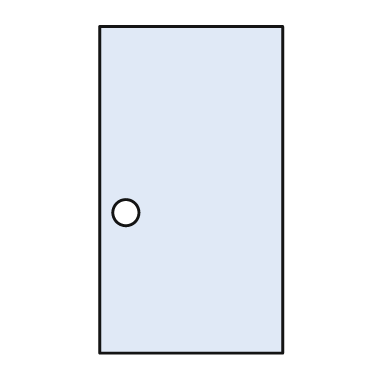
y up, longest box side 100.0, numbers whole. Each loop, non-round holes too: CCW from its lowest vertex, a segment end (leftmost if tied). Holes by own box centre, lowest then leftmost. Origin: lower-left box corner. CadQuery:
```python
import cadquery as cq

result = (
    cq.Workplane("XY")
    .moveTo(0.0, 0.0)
    .lineTo(56.0, 0.0)
    .lineTo(56.0, 100.0)
    .lineTo(0.0, 100.0)
    .close()
    .moveTo(8.0, 43.0)
    .circle(4.0)
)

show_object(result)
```